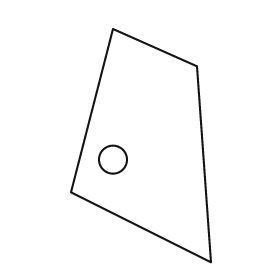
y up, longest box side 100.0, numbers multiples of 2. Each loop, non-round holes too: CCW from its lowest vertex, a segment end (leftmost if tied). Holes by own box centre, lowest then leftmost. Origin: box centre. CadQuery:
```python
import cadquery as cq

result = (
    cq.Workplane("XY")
    .moveTo(30.0, -50.0)
    .lineTo(24.0, 34.0)
    .lineTo(-12.0, 50.0)
    .lineTo(-30.0, -20.0)
    .close()
    .moveTo(-12.0, -6.0)
    .circle(6.0)
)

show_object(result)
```